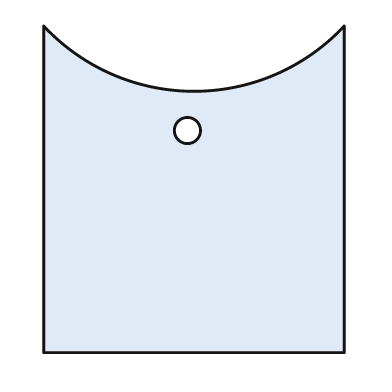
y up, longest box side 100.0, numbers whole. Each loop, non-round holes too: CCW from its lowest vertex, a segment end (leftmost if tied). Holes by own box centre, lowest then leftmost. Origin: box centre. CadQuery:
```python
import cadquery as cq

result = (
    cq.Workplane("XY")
    .moveTo(-46.0, -50.0)
    .lineTo(46.0, -50.0)
    .lineTo(46.0, 50.0)
    .threePointArc((0.0, 30.0), (-46.0, 50.0))
    .close()
    .moveTo(-2.0, 18.0)
    .circle(4.0)
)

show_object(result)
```